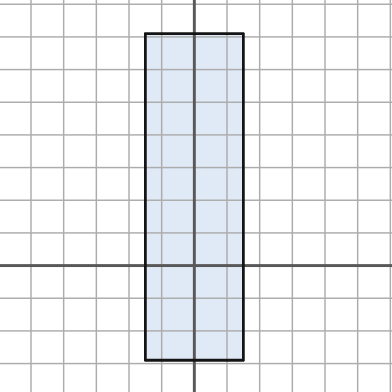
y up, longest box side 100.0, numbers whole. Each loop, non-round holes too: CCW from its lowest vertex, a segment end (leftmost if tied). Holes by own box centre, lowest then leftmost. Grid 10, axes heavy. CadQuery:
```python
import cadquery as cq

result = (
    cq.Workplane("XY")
    .moveTo(-15.0, -29.0)
    .lineTo(15.0, -29.0)
    .lineTo(15.0, 71.0)
    .lineTo(-15.0, 71.0)
    .close()
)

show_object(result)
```